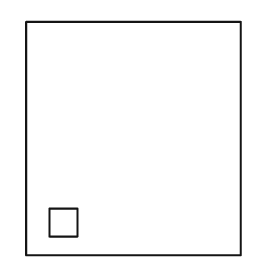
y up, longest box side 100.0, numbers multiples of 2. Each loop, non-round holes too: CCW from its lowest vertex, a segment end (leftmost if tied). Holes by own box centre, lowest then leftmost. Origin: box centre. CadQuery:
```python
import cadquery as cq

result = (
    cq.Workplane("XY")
    .moveTo(-46.0, -50.0)
    .lineTo(46.0, -50.0)
    .lineTo(46.0, 50.0)
    .lineTo(-46.0, 50.0)
    .close()
    .moveTo(-36.0, -42.0)
    .lineTo(-24.0, -42.0)
    .lineTo(-24.0, -30.0)
    .lineTo(-36.0, -30.0)
    .close()
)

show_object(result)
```